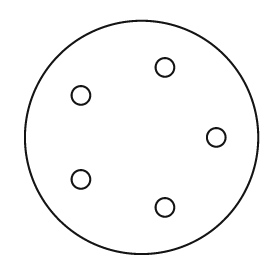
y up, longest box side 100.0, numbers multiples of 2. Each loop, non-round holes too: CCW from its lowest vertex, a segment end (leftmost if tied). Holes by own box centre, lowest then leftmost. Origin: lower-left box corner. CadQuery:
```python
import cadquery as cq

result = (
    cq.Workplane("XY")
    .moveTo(50.0, 50.0)
    .circle(50.0)
    .moveTo(60.0, 20.0)
    .circle(4.0)
    .moveTo(24.0, 32.0)
    .circle(4.0)
    .moveTo(82.0, 50.0)
    .circle(4.0)
    .moveTo(24.0, 68.0)
    .circle(4.0)
    .moveTo(60.0, 80.0)
    .circle(4.0)
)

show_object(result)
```